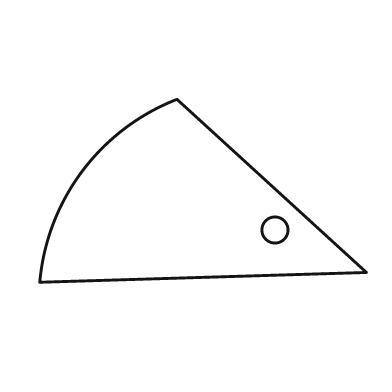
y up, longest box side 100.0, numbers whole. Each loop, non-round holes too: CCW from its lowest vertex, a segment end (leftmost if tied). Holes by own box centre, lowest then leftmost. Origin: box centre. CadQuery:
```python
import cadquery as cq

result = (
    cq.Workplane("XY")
    .moveTo(-50.0, -28.0)
    .lineTo(50.0, -25.0)
    .lineTo(-8.0, 28.0)
    .threePointArc((-37.0, 6.0), (-50.0, -28.0))
    .close()
    .moveTo(22.0, -12.0)
    .circle(4.0)
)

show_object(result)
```